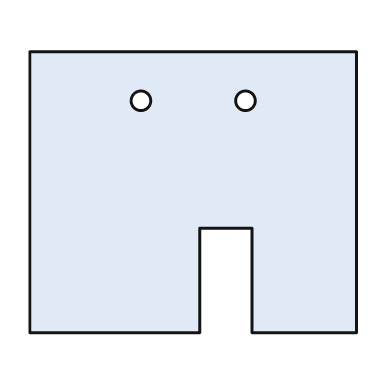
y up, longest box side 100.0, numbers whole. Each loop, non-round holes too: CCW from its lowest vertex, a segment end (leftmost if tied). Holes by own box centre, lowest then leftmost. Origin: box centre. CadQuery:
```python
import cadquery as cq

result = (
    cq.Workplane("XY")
    .moveTo(-50.0, -43.0)
    .lineTo(2.0, -43.0)
    .lineTo(2.0, -11.0)
    .lineTo(18.0, -11.0)
    .lineTo(18.0, -43.0)
    .lineTo(50.0, -43.0)
    .lineTo(50.0, 43.0)
    .lineTo(-50.0, 43.0)
    .close()
    .moveTo(-16.0, 28.0)
    .circle(3.0)
    .moveTo(16.0, 28.0)
    .circle(3.0)
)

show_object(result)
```